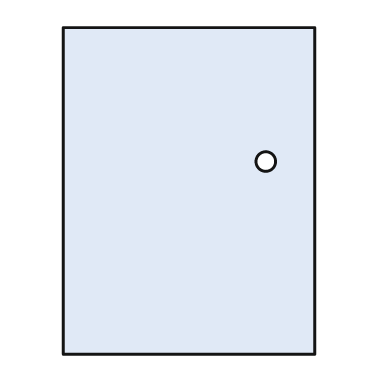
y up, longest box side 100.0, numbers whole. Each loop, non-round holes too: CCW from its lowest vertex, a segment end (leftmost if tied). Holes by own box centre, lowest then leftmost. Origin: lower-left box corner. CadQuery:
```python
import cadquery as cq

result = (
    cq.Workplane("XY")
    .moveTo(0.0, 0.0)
    .lineTo(77.0, 0.0)
    .lineTo(77.0, 100.0)
    .lineTo(0.0, 100.0)
    .close()
    .moveTo(62.0, 59.0)
    .circle(3.0)
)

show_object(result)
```